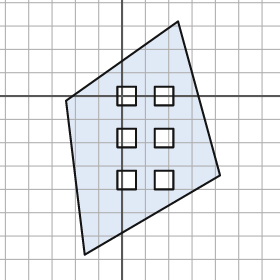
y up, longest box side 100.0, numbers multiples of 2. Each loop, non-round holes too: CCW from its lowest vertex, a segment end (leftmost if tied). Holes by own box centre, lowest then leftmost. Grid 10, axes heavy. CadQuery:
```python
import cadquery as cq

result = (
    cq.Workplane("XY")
    .moveTo(-16.0, -68.0)
    .lineTo(42.0, -34.0)
    .lineTo(24.0, 32.0)
    .lineTo(-24.0, -2.0)
    .close()
    .moveTo(-2.0, -40.0)
    .lineTo(6.0, -40.0)
    .lineTo(6.0, -32.0)
    .lineTo(-2.0, -32.0)
    .close()
    .moveTo(14.0, -40.0)
    .lineTo(22.0, -40.0)
    .lineTo(22.0, -32.0)
    .lineTo(14.0, -32.0)
    .close()
    .moveTo(-2.0, -22.0)
    .lineTo(6.0, -22.0)
    .lineTo(6.0, -14.0)
    .lineTo(-2.0, -14.0)
    .close()
    .moveTo(14.0, -22.0)
    .lineTo(22.0, -22.0)
    .lineTo(22.0, -14.0)
    .lineTo(14.0, -14.0)
    .close()
    .moveTo(-2.0, -4.0)
    .lineTo(6.0, -4.0)
    .lineTo(6.0, 4.0)
    .lineTo(-2.0, 4.0)
    .close()
    .moveTo(14.0, -4.0)
    .lineTo(22.0, -4.0)
    .lineTo(22.0, 4.0)
    .lineTo(14.0, 4.0)
    .close()
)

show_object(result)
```